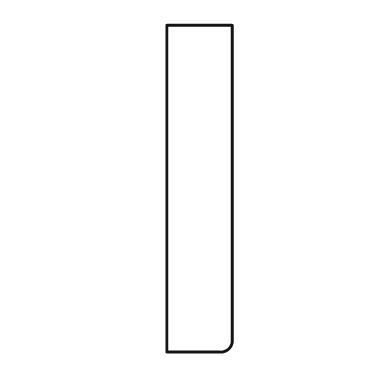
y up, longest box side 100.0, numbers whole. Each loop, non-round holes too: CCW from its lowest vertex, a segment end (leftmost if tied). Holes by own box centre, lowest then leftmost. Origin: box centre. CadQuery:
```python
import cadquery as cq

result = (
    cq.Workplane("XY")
    .moveTo(-10.0, -50.0)
    .lineTo(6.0, -50.0)
    .threePointArc((9.0, -49.0), (10.0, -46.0))
    .lineTo(10.0, 50.0)
    .lineTo(-10.0, 50.0)
    .close()
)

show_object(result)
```